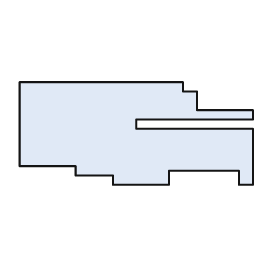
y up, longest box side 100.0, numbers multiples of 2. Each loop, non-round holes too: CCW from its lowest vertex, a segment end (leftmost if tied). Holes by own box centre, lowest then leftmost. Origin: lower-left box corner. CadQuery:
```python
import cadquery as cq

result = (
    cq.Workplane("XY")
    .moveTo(40.0, 0.0)
    .lineTo(64.0, 0.0)
    .lineTo(64.0, 6.0)
    .lineTo(94.0, 6.0)
    .lineTo(94.0, 0.0)
    .lineTo(100.0, 0.0)
    .lineTo(100.0, 24.0)
    .lineTo(50.0, 24.0)
    .lineTo(50.0, 28.0)
    .lineTo(100.0, 28.0)
    .lineTo(100.0, 32.0)
    .lineTo(76.0, 32.0)
    .lineTo(76.0, 40.0)
    .lineTo(70.0, 40.0)
    .lineTo(70.0, 44.0)
    .lineTo(0.0, 44.0)
    .lineTo(0.0, 8.0)
    .lineTo(24.0, 8.0)
    .lineTo(24.0, 4.0)
    .lineTo(40.0, 4.0)
    .close()
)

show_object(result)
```